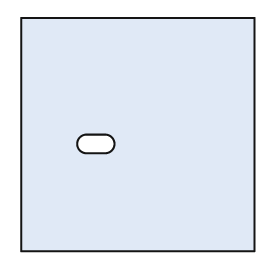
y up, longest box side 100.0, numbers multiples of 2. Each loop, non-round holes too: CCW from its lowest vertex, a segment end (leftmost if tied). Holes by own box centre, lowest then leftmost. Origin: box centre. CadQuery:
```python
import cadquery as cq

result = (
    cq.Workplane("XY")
    .moveTo(-50.0, -50.0)
    .lineTo(50.0, -50.0)
    .lineTo(50.0, 50.0)
    .lineTo(-50.0, 50.0)
    .close()
    .moveTo(-22.0, -8.0)
    .lineTo(-14.0, -8.0)
    .threePointArc((-10.0, -4.0), (-14.0, 0.0))
    .lineTo(-22.0, 0.0)
    .threePointArc((-26.0, -4.0), (-22.0, -8.0))
    .close()
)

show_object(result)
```